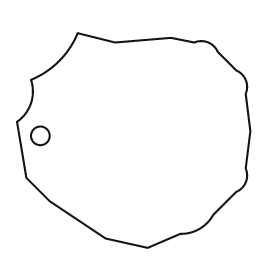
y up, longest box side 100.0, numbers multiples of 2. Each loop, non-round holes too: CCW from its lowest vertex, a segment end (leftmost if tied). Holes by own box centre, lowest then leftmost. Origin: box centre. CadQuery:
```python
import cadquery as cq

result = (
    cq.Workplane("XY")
    .moveTo(6.0, -46.0)
    .lineTo(20.0, -40.0)
    .threePointArc((28.0, -38.0), (34.0, -32.0))
    .lineTo(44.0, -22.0)
    .threePointArc((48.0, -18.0), (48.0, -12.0))
    .lineTo(50.0, 4.0)
    .lineTo(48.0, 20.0)
    .threePointArc((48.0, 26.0), (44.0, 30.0))
    .lineTo(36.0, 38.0)
    .threePointArc((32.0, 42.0), (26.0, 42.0))
    .lineTo(16.0, 44.0)
    .lineTo(-8.0, 42.0)
    .lineTo(-24.0, 46.0)
    .threePointArc((-32.0, 34.0), (-44.0, 26.0))
    .threePointArc((-44.0, 16.0), (-50.0, 8.0))
    .lineTo(-46.0, -16.0)
    .lineTo(-36.0, -26.0)
    .lineTo(-12.0, -42.0)
    .close()
    .moveTo(-40.0, 2.0)
    .circle(4.0)
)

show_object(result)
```